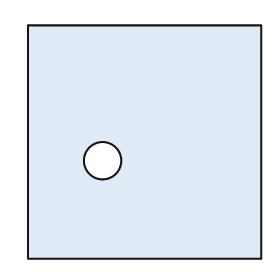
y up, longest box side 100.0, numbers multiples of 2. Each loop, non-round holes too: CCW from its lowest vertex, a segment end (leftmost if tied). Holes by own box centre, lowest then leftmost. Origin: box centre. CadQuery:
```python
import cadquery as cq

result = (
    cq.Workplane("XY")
    .moveTo(-50.0, -50.0)
    .lineTo(50.0, -50.0)
    .lineTo(50.0, 50.0)
    .lineTo(-50.0, 50.0)
    .close()
    .moveTo(-18.0, -8.0)
    .circle(8.0)
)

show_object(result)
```